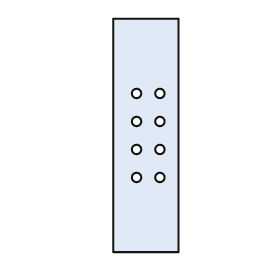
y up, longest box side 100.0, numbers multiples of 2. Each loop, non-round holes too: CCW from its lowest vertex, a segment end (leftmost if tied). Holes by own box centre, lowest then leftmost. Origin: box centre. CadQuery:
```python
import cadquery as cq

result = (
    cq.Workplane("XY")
    .moveTo(-14.0, -50.0)
    .lineTo(14.0, -50.0)
    .lineTo(14.0, 50.0)
    .lineTo(-14.0, 50.0)
    .close()
    .moveTo(-4.0, -18.0)
    .circle(2.0)
    .moveTo(6.0, -18.0)
    .circle(2.0)
    .moveTo(-4.0, -6.0)
    .circle(2.0)
    .moveTo(6.0, -6.0)
    .circle(2.0)
    .moveTo(-4.0, 6.0)
    .circle(2.0)
    .moveTo(6.0, 6.0)
    .circle(2.0)
    .moveTo(-4.0, 18.0)
    .circle(2.0)
    .moveTo(6.0, 18.0)
    .circle(2.0)
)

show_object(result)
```